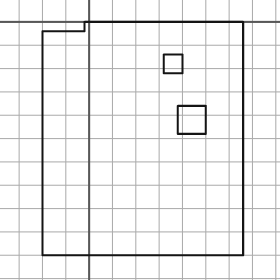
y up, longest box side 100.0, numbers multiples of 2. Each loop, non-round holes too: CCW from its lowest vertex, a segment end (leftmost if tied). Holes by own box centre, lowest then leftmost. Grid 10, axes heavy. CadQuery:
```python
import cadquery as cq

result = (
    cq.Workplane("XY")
    .moveTo(-20.0, -100.0)
    .lineTo(66.0, -100.0)
    .lineTo(66.0, 0.0)
    .lineTo(-2.0, 0.0)
    .lineTo(-2.0, -4.0)
    .lineTo(-20.0, -4.0)
    .close()
    .moveTo(38.0, -48.0)
    .lineTo(50.0, -48.0)
    .lineTo(50.0, -36.0)
    .lineTo(38.0, -36.0)
    .close()
    .moveTo(32.0, -22.0)
    .lineTo(40.0, -22.0)
    .lineTo(40.0, -14.0)
    .lineTo(32.0, -14.0)
    .close()
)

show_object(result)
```